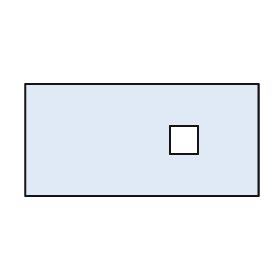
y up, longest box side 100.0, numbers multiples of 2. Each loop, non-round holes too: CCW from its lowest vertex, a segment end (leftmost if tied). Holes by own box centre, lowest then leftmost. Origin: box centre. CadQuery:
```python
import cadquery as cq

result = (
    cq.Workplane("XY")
    .moveTo(-50.0, -24.0)
    .lineTo(50.0, -24.0)
    .lineTo(50.0, 24.0)
    .lineTo(-50.0, 24.0)
    .close()
    .moveTo(12.0, -6.0)
    .lineTo(24.0, -6.0)
    .lineTo(24.0, 6.0)
    .lineTo(12.0, 6.0)
    .close()
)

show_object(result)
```